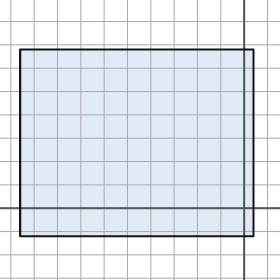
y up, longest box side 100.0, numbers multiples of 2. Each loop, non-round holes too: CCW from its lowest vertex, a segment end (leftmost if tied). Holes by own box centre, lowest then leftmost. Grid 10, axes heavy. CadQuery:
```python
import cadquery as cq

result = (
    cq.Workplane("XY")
    .moveTo(-96.0, -12.0)
    .lineTo(4.0, -12.0)
    .lineTo(4.0, 68.0)
    .lineTo(-96.0, 68.0)
    .close()
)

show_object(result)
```